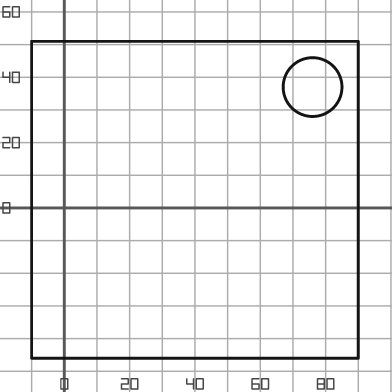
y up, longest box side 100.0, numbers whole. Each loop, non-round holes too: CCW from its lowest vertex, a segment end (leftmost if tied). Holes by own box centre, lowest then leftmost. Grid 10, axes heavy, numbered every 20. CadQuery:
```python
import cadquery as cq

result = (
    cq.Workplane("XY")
    .moveTo(-10.0, -46.0)
    .lineTo(90.0, -46.0)
    .lineTo(90.0, 51.0)
    .lineTo(-10.0, 51.0)
    .close()
    .moveTo(76.0, 37.0)
    .circle(9.0)
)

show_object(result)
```